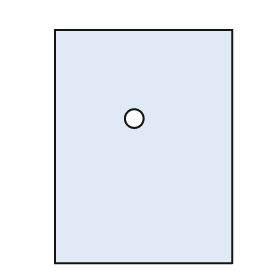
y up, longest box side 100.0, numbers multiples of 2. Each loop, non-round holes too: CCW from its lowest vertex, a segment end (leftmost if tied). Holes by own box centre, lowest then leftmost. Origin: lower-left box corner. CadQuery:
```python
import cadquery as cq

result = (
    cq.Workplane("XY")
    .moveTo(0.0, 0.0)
    .lineTo(76.0, 0.0)
    .lineTo(76.0, 100.0)
    .lineTo(0.0, 100.0)
    .close()
    .moveTo(34.0, 62.0)
    .circle(4.0)
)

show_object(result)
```